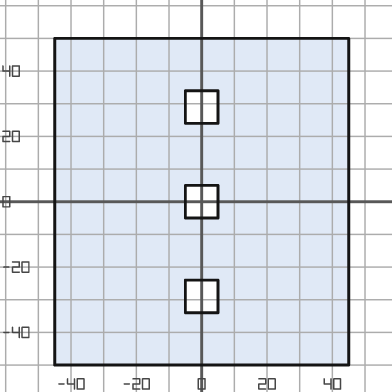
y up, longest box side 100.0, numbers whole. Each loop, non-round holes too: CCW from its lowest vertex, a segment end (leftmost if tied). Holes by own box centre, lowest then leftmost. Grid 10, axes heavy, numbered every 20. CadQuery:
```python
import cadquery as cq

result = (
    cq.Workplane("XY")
    .moveTo(-45.0, -50.0)
    .lineTo(45.0, -50.0)
    .lineTo(45.0, 50.0)
    .lineTo(-45.0, 50.0)
    .close()
    .moveTo(-5.0, -34.0)
    .lineTo(5.0, -34.0)
    .lineTo(5.0, -24.0)
    .lineTo(-5.0, -24.0)
    .close()
    .moveTo(-5.0, -5.0)
    .lineTo(5.0, -5.0)
    .lineTo(5.0, 5.0)
    .lineTo(-5.0, 5.0)
    .close()
    .moveTo(-5.0, 24.0)
    .lineTo(5.0, 24.0)
    .lineTo(5.0, 34.0)
    .lineTo(-5.0, 34.0)
    .close()
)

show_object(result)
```